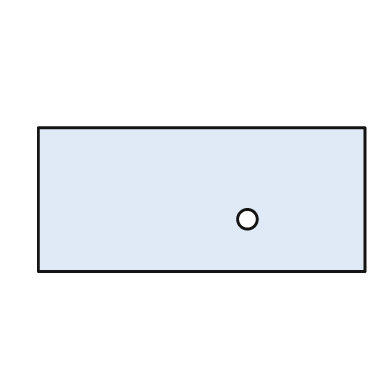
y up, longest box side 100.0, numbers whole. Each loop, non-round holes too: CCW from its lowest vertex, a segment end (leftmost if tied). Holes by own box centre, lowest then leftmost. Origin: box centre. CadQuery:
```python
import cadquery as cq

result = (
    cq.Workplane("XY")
    .moveTo(-50.0, -22.0)
    .lineTo(50.0, -22.0)
    .lineTo(50.0, 22.0)
    .lineTo(-50.0, 22.0)
    .close()
    .moveTo(14.0, -6.0)
    .circle(3.0)
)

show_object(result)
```